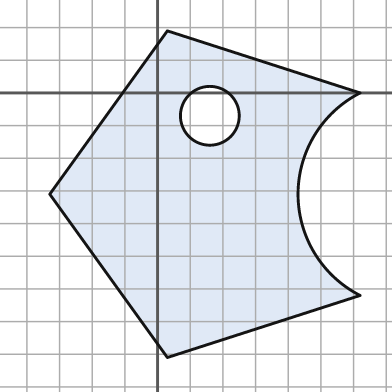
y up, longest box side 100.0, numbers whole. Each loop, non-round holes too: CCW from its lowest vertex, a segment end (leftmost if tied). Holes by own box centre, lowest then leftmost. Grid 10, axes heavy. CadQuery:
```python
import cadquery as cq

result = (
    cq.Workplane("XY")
    .moveTo(3.0, -81.0)
    .lineTo(62.0, -62.0)
    .threePointArc((43.0, -31.0), (62.0, 0.0))
    .lineTo(3.0, 19.0)
    .lineTo(-33.0, -31.0)
    .close()
    .moveTo(16.0, -7.0)
    .circle(9.0)
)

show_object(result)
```